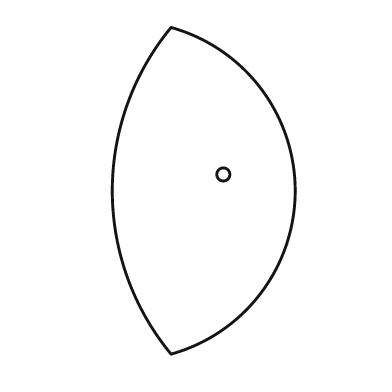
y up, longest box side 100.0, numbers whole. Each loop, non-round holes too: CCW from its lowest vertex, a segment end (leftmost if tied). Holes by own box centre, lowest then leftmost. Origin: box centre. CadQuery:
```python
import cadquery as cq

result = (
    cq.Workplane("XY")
    .moveTo(-10.0, -50.0)
    .threePointArc((28.0, 0.0), (-10.0, 50.0))
    .threePointArc((-28.0, 0.0), (-10.0, -50.0))
    .close()
    .moveTo(6.0, 5.0)
    .circle(2.0)
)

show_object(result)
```